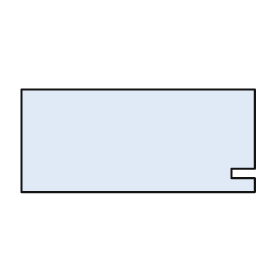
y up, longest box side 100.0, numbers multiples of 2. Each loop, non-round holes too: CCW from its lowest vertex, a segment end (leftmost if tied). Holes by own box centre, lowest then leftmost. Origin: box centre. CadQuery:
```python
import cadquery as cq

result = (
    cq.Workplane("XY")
    .moveTo(-50.0, -22.0)
    .lineTo(50.0, -22.0)
    .lineTo(50.0, -16.0)
    .lineTo(40.0, -16.0)
    .lineTo(40.0, -12.0)
    .lineTo(50.0, -12.0)
    .lineTo(50.0, 22.0)
    .lineTo(-50.0, 22.0)
    .close()
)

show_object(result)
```